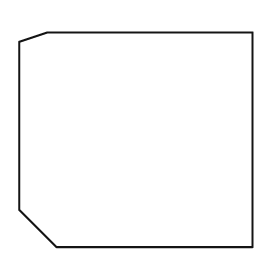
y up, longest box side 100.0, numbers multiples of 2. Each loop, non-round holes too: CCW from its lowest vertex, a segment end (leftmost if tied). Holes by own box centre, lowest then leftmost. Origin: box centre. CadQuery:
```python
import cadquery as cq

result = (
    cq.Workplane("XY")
    .moveTo(-34.0, -46.0)
    .lineTo(50.0, -46.0)
    .lineTo(50.0, 46.0)
    .lineTo(-38.0, 46.0)
    .lineTo(-50.0, 42.0)
    .lineTo(-50.0, -30.0)
    .close()
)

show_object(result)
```